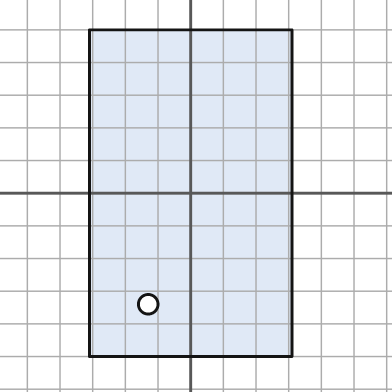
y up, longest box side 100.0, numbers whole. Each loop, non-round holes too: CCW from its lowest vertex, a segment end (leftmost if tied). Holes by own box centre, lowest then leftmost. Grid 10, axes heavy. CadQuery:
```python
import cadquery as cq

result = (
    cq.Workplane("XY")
    .moveTo(-31.0, -50.0)
    .lineTo(31.0, -50.0)
    .lineTo(31.0, 50.0)
    .lineTo(-31.0, 50.0)
    .close()
    .moveTo(-13.0, -34.0)
    .circle(3.0)
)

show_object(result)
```